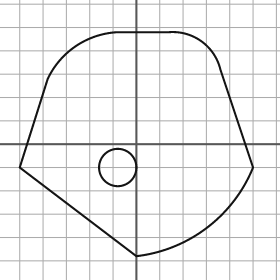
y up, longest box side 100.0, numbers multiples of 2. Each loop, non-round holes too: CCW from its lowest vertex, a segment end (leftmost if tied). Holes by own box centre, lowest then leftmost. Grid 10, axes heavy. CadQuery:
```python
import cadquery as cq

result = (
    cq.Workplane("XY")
    .moveTo(0.0, -48.0)
    .threePointArc((30.0, -36.0), (50.0, -10.0))
    .lineTo(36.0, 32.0)
    .threePointArc((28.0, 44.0), (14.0, 48.0))
    .lineTo(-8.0, 48.0)
    .threePointArc((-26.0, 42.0), (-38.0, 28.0))
    .lineTo(-50.0, -10.0)
    .close()
    .moveTo(-8.0, -10.0)
    .circle(8.0)
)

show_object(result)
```